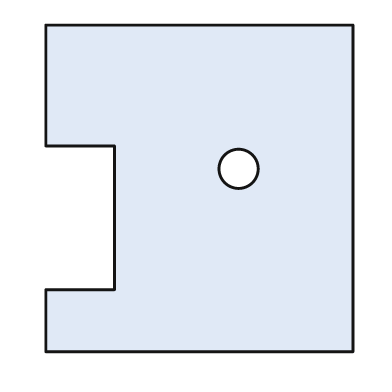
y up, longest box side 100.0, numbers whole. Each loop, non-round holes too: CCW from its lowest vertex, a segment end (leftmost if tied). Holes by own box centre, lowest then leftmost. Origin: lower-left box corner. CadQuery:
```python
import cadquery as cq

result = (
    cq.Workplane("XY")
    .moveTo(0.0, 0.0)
    .lineTo(94.0, 0.0)
    .lineTo(94.0, 100.0)
    .lineTo(0.0, 100.0)
    .lineTo(0.0, 63.0)
    .lineTo(21.0, 63.0)
    .lineTo(21.0, 19.0)
    .lineTo(0.0, 19.0)
    .close()
    .moveTo(59.0, 56.0)
    .circle(6.0)
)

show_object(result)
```